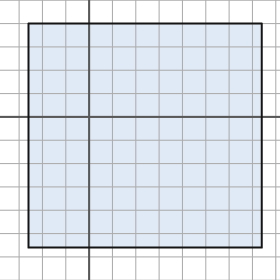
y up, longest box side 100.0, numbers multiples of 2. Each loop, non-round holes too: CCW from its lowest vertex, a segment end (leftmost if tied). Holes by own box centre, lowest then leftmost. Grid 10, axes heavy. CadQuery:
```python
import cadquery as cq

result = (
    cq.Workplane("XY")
    .moveTo(-26.0, -56.0)
    .lineTo(74.0, -56.0)
    .lineTo(74.0, 40.0)
    .lineTo(-26.0, 40.0)
    .close()
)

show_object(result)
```